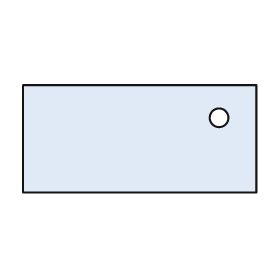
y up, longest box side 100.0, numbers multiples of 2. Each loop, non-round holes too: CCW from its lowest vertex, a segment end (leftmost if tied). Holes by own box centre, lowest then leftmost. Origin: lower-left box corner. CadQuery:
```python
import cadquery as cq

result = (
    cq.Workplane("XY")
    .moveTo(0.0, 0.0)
    .lineTo(100.0, 0.0)
    .lineTo(100.0, 46.0)
    .lineTo(0.0, 46.0)
    .close()
    .moveTo(84.0, 32.0)
    .circle(4.0)
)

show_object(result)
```